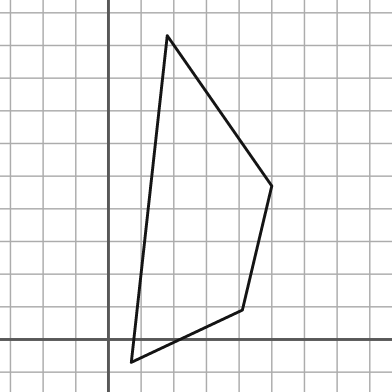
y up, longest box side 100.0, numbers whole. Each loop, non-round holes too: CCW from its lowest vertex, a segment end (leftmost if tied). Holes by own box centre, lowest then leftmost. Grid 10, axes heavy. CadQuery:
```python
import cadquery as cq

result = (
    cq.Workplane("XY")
    .moveTo(7.0, -7.0)
    .lineTo(41.0, 9.0)
    .lineTo(50.0, 47.0)
    .lineTo(18.0, 93.0)
    .close()
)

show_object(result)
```